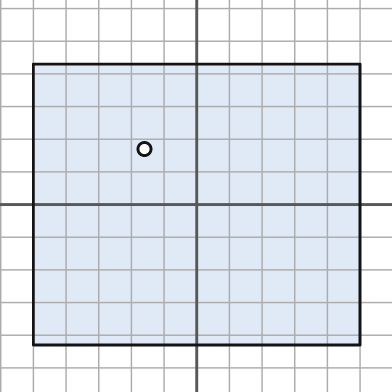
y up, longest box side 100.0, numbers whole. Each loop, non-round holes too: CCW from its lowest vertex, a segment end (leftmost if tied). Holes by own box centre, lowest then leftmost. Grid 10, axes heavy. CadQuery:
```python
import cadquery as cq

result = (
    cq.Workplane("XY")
    .moveTo(-50.0, -43.0)
    .lineTo(50.0, -43.0)
    .lineTo(50.0, 43.0)
    .lineTo(-50.0, 43.0)
    .close()
    .moveTo(-16.0, 17.0)
    .circle(2.0)
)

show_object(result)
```